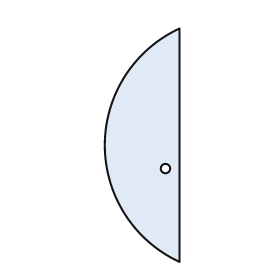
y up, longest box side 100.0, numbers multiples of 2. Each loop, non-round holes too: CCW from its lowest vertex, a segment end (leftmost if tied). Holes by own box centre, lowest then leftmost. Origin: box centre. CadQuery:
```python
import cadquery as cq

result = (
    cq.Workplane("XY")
    .moveTo(16.0, -50.0)
    .lineTo(16.0, 50.0)
    .threePointArc((-16.0, 0.0), (16.0, -50.0))
    .close()
    .moveTo(10.0, -10.0)
    .circle(2.0)
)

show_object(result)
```